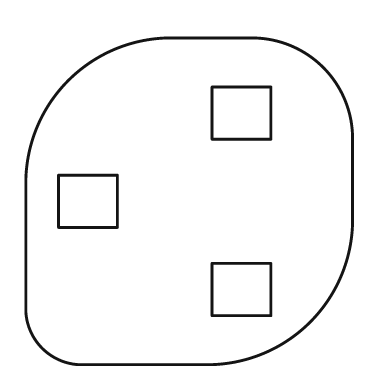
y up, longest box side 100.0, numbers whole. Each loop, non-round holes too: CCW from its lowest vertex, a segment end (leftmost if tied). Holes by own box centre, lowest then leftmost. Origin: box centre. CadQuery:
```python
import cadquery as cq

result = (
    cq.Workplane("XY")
    .moveTo(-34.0, -50.0)
    .lineTo(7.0, -50.0)
    .threePointArc((37.0, -37.0), (50.0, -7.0))
    .lineTo(50.0, 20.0)
    .threePointArc((41.0, 41.0), (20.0, 50.0))
    .lineTo(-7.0, 50.0)
    .threePointArc((-37.0, 37.0), (-50.0, 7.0))
    .lineTo(-50.0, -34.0)
    .threePointArc((-45.0, -45.0), (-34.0, -50.0))
    .close()
    .moveTo(7.0, -35.0)
    .lineTo(25.0, -35.0)
    .lineTo(25.0, -19.0)
    .lineTo(7.0, -19.0)
    .close()
    .moveTo(-40.0, -8.0)
    .lineTo(-22.0, -8.0)
    .lineTo(-22.0, 8.0)
    .lineTo(-40.0, 8.0)
    .close()
    .moveTo(7.0, 19.0)
    .lineTo(25.0, 19.0)
    .lineTo(25.0, 35.0)
    .lineTo(7.0, 35.0)
    .close()
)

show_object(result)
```